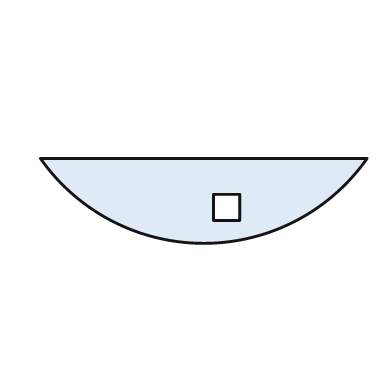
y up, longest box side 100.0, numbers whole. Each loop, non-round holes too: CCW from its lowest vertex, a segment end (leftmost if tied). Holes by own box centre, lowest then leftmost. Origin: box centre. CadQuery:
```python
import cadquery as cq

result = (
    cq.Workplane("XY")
    .moveTo(-50.0, 13.0)
    .threePointArc((0.0, -13.0), (50.0, 13.0))
    .close()
    .moveTo(3.0, -6.0)
    .lineTo(11.0, -6.0)
    .lineTo(11.0, 2.0)
    .lineTo(3.0, 2.0)
    .close()
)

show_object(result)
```